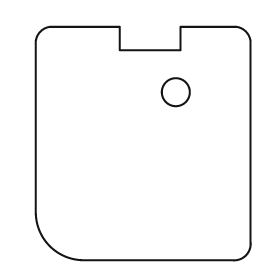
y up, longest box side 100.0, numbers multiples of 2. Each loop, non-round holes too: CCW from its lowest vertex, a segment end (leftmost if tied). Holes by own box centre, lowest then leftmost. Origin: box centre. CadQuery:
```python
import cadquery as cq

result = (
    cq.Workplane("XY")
    .moveTo(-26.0, -50.0)
    .lineTo(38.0, -50.0)
    .threePointArc((44.0, -48.0), (46.0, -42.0))
    .lineTo(46.0, 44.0)
    .threePointArc((44.0, 48.0), (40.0, 50.0))
    .lineTo(16.0, 50.0)
    .lineTo(16.0, 40.0)
    .lineTo(-10.0, 40.0)
    .lineTo(-10.0, 50.0)
    .lineTo(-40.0, 50.0)
    .threePointArc((-44.0, 48.0), (-46.0, 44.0))
    .lineTo(-46.0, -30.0)
    .threePointArc((-40.0, -44.0), (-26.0, -50.0))
    .close()
    .moveTo(14.0, 22.0)
    .circle(6.0)
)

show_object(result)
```